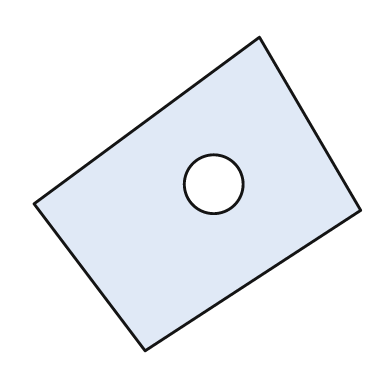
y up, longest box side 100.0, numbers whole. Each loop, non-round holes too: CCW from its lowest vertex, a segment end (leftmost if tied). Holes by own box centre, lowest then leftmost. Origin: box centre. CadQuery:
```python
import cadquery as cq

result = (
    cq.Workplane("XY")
    .moveTo(-16.0, -48.0)
    .lineTo(50.0, -5.0)
    .lineTo(19.0, 48.0)
    .lineTo(-50.0, -3.0)
    .close()
    .moveTo(5.0, 3.0)
    .circle(9.0)
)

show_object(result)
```